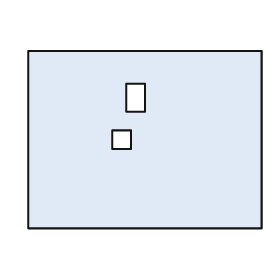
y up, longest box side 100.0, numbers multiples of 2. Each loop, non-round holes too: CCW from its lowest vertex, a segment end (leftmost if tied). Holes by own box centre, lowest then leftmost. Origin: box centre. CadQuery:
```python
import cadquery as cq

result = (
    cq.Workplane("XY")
    .moveTo(-50.0, -38.0)
    .lineTo(50.0, -38.0)
    .lineTo(50.0, 38.0)
    .lineTo(-50.0, 38.0)
    .close()
    .moveTo(-14.0, -4.0)
    .lineTo(-6.0, -4.0)
    .lineTo(-6.0, 4.0)
    .lineTo(-14.0, 4.0)
    .close()
    .moveTo(-8.0, 12.0)
    .lineTo(0.0, 12.0)
    .lineTo(0.0, 24.0)
    .lineTo(-8.0, 24.0)
    .close()
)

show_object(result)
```